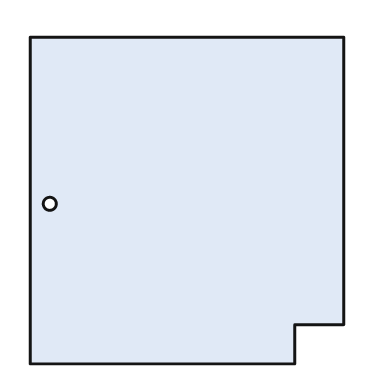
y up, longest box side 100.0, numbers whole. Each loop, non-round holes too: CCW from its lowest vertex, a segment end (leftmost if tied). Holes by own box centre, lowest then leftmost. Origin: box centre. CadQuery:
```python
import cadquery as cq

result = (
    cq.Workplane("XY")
    .moveTo(-48.0, -50.0)
    .lineTo(33.0, -50.0)
    .lineTo(33.0, -38.0)
    .lineTo(48.0, -38.0)
    .lineTo(48.0, 50.0)
    .lineTo(-48.0, 50.0)
    .close()
    .moveTo(-42.0, -1.0)
    .circle(2.0)
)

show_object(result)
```